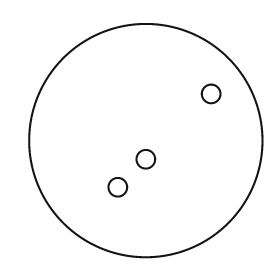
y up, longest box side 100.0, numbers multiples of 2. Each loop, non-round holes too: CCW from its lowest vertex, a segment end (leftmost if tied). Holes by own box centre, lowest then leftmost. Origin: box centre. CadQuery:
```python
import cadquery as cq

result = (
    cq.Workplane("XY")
    .moveTo(0.0, 0.0)
    .circle(50.0)
    .moveTo(-12.0, -20.0)
    .circle(4.0)
    .moveTo(0.0, -8.0)
    .circle(4.0)
    .moveTo(28.0, 20.0)
    .circle(4.0)
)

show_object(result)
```